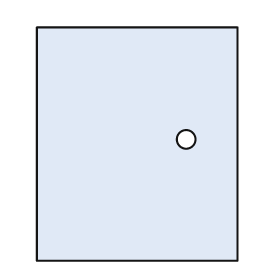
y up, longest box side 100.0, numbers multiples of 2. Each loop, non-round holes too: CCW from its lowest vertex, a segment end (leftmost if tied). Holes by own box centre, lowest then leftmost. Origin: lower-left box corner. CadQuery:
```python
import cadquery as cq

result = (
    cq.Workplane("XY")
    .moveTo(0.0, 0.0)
    .lineTo(86.0, 0.0)
    .lineTo(86.0, 100.0)
    .lineTo(0.0, 100.0)
    .close()
    .moveTo(64.0, 52.0)
    .circle(4.0)
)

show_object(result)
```